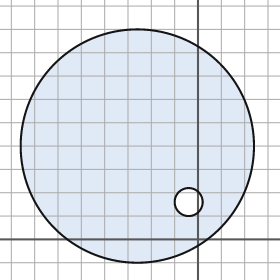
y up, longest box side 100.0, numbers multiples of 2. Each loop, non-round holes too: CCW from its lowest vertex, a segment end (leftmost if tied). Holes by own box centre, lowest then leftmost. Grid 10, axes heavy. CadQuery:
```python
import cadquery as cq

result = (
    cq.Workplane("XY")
    .moveTo(-26.0, 40.0)
    .circle(50.0)
    .moveTo(-4.0, 16.0)
    .circle(6.0)
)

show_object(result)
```